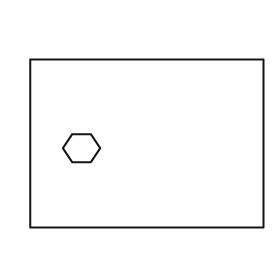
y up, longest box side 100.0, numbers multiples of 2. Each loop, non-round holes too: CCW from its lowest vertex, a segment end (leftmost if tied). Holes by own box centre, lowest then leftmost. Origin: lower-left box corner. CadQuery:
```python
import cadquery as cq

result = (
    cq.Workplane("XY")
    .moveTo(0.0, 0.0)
    .lineTo(100.0, 0.0)
    .lineTo(100.0, 72.0)
    .lineTo(0.0, 72.0)
    .close()
    .moveTo(18.0, 28.0)
    .lineTo(26.0, 28.0)
    .lineTo(30.0, 34.0)
    .lineTo(26.0, 40.0)
    .lineTo(18.0, 40.0)
    .lineTo(14.0, 34.0)
    .close()
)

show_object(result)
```